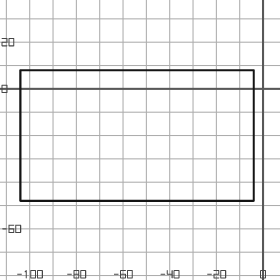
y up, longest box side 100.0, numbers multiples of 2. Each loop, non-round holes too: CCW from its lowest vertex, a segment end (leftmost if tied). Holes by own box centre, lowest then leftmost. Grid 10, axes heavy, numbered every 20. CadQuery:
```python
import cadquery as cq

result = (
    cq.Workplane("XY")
    .moveTo(-104.0, -48.0)
    .lineTo(-4.0, -48.0)
    .lineTo(-4.0, 8.0)
    .lineTo(-104.0, 8.0)
    .close()
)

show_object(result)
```